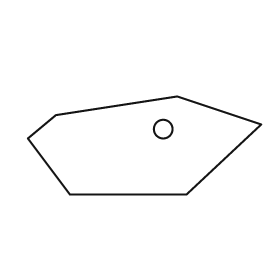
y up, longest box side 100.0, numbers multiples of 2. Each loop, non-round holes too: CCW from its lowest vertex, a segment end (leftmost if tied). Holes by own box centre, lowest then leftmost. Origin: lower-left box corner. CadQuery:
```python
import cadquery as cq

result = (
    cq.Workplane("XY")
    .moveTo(18.0, 0.0)
    .lineTo(68.0, 0.0)
    .lineTo(100.0, 30.0)
    .lineTo(64.0, 42.0)
    .lineTo(12.0, 34.0)
    .lineTo(0.0, 24.0)
    .close()
    .moveTo(58.0, 28.0)
    .circle(4.0)
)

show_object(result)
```